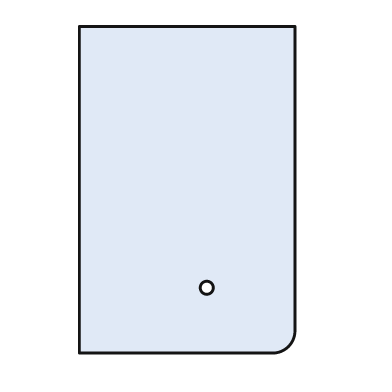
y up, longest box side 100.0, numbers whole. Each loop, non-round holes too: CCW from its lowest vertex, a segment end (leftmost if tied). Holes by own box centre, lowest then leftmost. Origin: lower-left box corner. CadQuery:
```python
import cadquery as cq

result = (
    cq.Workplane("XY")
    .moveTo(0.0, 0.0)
    .lineTo(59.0, 0.0)
    .threePointArc((64.0, 2.0), (66.0, 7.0))
    .lineTo(66.0, 100.0)
    .lineTo(0.0, 100.0)
    .close()
    .moveTo(39.0, 20.0)
    .circle(2.0)
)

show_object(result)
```